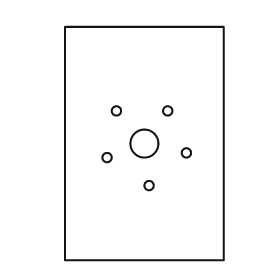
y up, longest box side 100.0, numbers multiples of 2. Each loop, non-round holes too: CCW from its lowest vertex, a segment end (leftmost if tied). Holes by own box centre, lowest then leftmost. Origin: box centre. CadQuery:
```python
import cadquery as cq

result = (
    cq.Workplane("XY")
    .moveTo(-34.0, -50.0)
    .lineTo(34.0, -50.0)
    .lineTo(34.0, 50.0)
    .lineTo(-34.0, 50.0)
    .close()
    .moveTo(2.0, -18.0)
    .circle(2.0)
    .moveTo(-16.0, -6.0)
    .circle(2.0)
    .moveTo(18.0, -4.0)
    .circle(2.0)
    .moveTo(0.0, 0.0)
    .circle(6.0)
    .moveTo(-12.0, 14.0)
    .circle(2.0)
    .moveTo(10.0, 14.0)
    .circle(2.0)
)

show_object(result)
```